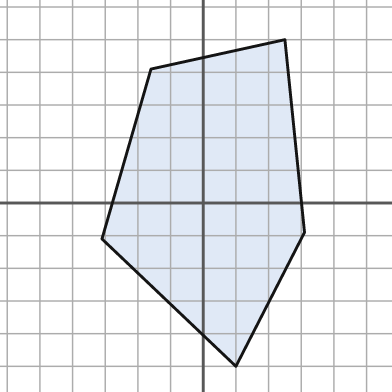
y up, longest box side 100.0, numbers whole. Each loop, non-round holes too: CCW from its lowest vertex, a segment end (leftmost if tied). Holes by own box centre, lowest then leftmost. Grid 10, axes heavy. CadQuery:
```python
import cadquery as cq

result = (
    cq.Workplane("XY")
    .moveTo(10.0, -50.0)
    .lineTo(31.0, -9.0)
    .lineTo(25.0, 50.0)
    .lineTo(-16.0, 41.0)
    .lineTo(-31.0, -11.0)
    .close()
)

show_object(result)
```